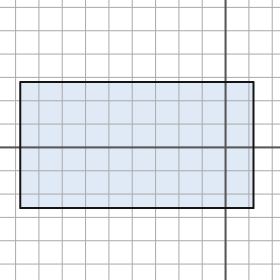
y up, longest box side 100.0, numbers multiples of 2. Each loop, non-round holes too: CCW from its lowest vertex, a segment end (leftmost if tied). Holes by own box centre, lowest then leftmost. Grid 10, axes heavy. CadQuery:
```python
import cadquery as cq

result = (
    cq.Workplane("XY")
    .moveTo(-88.0, -26.0)
    .lineTo(12.0, -26.0)
    .lineTo(12.0, 28.0)
    .lineTo(-88.0, 28.0)
    .close()
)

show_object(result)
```